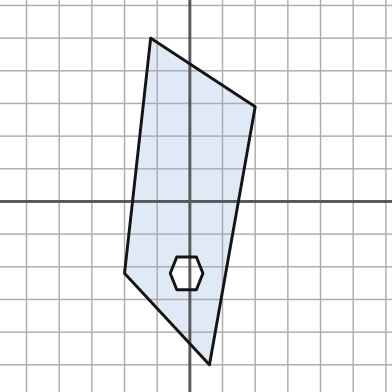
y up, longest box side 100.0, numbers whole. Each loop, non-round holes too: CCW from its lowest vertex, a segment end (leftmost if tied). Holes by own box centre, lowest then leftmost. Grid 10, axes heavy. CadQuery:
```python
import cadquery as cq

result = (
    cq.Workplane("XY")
    .moveTo(6.0, -50.0)
    .lineTo(20.0, 29.0)
    .lineTo(-12.0, 50.0)
    .lineTo(-20.0, -22.0)
    .close()
    .moveTo(-4.0, -27.0)
    .lineTo(2.0, -27.0)
    .lineTo(4.0, -22.0)
    .lineTo(2.0, -17.0)
    .lineTo(-4.0, -17.0)
    .lineTo(-6.0, -22.0)
    .close()
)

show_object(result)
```